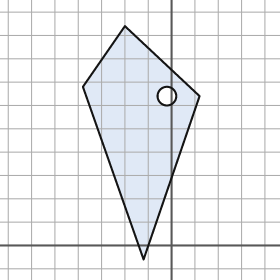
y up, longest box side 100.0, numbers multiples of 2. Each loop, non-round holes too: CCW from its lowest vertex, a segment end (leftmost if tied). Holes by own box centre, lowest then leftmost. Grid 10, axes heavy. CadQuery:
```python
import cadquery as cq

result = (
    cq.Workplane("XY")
    .moveTo(-12.0, -6.0)
    .lineTo(12.0, 64.0)
    .lineTo(-20.0, 94.0)
    .lineTo(-38.0, 68.0)
    .close()
    .moveTo(-2.0, 64.0)
    .circle(4.0)
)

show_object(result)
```